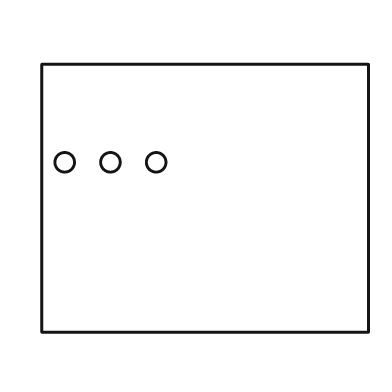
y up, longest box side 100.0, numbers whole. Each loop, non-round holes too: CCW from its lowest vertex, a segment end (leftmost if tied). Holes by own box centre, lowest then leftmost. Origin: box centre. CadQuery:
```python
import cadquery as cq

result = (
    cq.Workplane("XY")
    .moveTo(-50.0, -41.0)
    .lineTo(50.0, -41.0)
    .lineTo(50.0, 41.0)
    .lineTo(-50.0, 41.0)
    .close()
    .moveTo(-43.0, 11.0)
    .circle(3.0)
    .moveTo(-29.0, 11.0)
    .circle(3.0)
    .moveTo(-15.0, 11.0)
    .circle(3.0)
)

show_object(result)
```